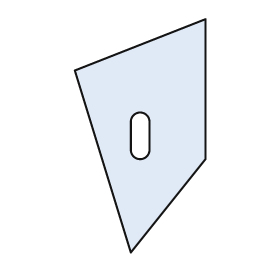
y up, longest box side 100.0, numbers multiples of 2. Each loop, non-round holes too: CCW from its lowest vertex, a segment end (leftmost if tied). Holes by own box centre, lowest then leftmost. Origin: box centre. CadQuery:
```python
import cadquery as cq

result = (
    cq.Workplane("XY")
    .moveTo(-4.0, -50.0)
    .lineTo(28.0, -10.0)
    .lineTo(28.0, 50.0)
    .lineTo(-28.0, 28.0)
    .close()
    .moveTo(-4.0, -6.0)
    .threePointArc((0.0, -10.0), (4.0, -6.0))
    .lineTo(4.0, 6.0)
    .threePointArc((0.0, 10.0), (-4.0, 6.0))
    .close()
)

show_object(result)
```